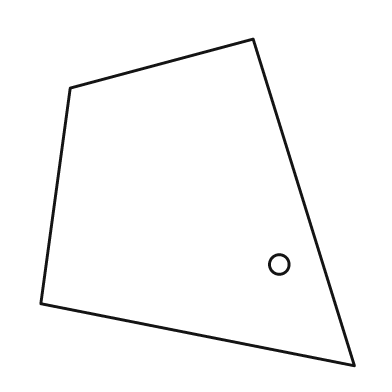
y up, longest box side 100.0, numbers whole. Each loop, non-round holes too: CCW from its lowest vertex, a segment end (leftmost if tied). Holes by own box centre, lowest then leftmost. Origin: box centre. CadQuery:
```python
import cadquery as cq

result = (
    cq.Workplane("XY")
    .moveTo(48.0, -50.0)
    .lineTo(17.0, 50.0)
    .lineTo(-39.0, 35.0)
    .lineTo(-48.0, -31.0)
    .close()
    .moveTo(25.0, -19.0)
    .circle(3.0)
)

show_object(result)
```